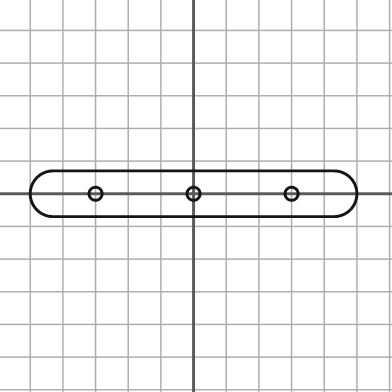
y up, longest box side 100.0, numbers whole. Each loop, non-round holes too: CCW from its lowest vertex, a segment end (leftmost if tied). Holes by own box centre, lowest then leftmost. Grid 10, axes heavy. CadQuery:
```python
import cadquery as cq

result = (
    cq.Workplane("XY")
    .moveTo(-43.0, -7.0)
    .lineTo(43.0, -7.0)
    .threePointArc((50.0, 0.0), (43.0, 7.0))
    .lineTo(-43.0, 7.0)
    .threePointArc((-50.0, 0.0), (-43.0, -7.0))
    .close()
    .moveTo(-30.0, 0.0)
    .circle(2.0)
    .moveTo(0.0, 0.0)
    .circle(2.0)
    .moveTo(30.0, 0.0)
    .circle(2.0)
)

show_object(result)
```